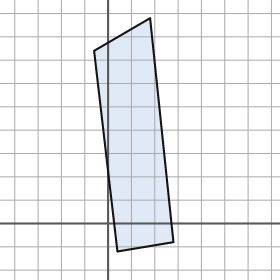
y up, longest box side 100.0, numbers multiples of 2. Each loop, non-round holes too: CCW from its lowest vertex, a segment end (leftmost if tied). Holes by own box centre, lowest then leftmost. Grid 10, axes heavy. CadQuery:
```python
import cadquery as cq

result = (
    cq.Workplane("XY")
    .moveTo(4.0, -12.0)
    .lineTo(28.0, -8.0)
    .lineTo(18.0, 88.0)
    .lineTo(-6.0, 74.0)
    .close()
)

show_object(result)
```